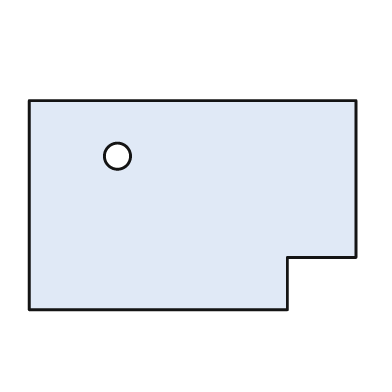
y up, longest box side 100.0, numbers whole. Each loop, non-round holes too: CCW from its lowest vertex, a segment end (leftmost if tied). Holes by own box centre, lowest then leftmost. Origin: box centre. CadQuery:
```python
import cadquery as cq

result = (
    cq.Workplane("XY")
    .moveTo(-50.0, -32.0)
    .lineTo(29.0, -32.0)
    .lineTo(29.0, -16.0)
    .lineTo(50.0, -16.0)
    .lineTo(50.0, 32.0)
    .lineTo(-50.0, 32.0)
    .close()
    .moveTo(-23.0, 15.0)
    .circle(4.0)
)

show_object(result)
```